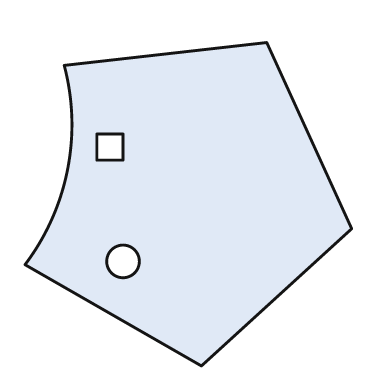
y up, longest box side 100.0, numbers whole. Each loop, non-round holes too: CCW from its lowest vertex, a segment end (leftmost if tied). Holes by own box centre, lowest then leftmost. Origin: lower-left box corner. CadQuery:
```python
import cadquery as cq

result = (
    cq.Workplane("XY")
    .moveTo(54.0, 0.0)
    .lineTo(100.0, 42.0)
    .lineTo(74.0, 99.0)
    .lineTo(12.0, 92.0)
    .threePointArc((13.0, 60.0), (0.0, 31.0))
    .close()
    .moveTo(30.0, 32.0)
    .circle(5.0)
    .moveTo(22.0, 63.0)
    .lineTo(30.0, 63.0)
    .lineTo(30.0, 71.0)
    .lineTo(22.0, 71.0)
    .close()
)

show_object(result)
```